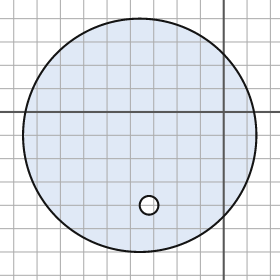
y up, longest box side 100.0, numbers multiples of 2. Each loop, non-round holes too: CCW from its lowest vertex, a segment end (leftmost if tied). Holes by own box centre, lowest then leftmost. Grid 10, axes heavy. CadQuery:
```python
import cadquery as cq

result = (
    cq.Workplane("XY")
    .moveTo(-36.0, -10.0)
    .circle(50.0)
    .moveTo(-32.0, -40.0)
    .circle(4.0)
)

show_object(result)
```